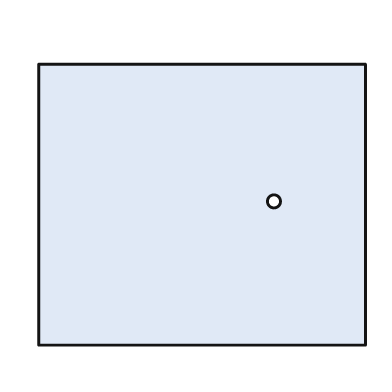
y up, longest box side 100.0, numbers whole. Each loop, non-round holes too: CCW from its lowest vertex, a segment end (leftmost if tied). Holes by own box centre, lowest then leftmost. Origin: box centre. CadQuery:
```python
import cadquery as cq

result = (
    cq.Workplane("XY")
    .moveTo(-50.0, -43.0)
    .lineTo(50.0, -43.0)
    .lineTo(50.0, 43.0)
    .lineTo(-50.0, 43.0)
    .close()
    .moveTo(22.0, 1.0)
    .circle(2.0)
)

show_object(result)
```